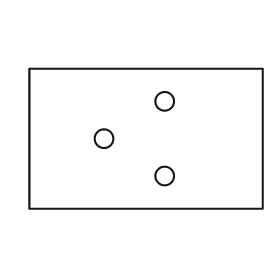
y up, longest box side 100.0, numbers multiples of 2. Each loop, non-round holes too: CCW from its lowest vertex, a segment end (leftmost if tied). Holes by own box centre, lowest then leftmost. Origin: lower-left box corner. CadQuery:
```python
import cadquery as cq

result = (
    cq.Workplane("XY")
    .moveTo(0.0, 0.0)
    .lineTo(100.0, 0.0)
    .lineTo(100.0, 60.0)
    .lineTo(0.0, 60.0)
    .close()
    .moveTo(58.0, 14.0)
    .circle(4.0)
    .moveTo(32.0, 30.0)
    .circle(4.0)
    .moveTo(58.0, 46.0)
    .circle(4.0)
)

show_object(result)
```